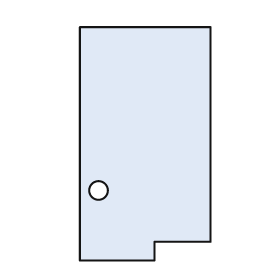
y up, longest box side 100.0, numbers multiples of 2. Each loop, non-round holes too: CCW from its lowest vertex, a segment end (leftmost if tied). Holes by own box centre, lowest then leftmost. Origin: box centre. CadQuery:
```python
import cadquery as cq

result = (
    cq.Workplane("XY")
    .moveTo(-28.0, -50.0)
    .lineTo(4.0, -50.0)
    .lineTo(4.0, -42.0)
    .lineTo(28.0, -42.0)
    .lineTo(28.0, 50.0)
    .lineTo(-28.0, 50.0)
    .close()
    .moveTo(-20.0, -20.0)
    .circle(4.0)
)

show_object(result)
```